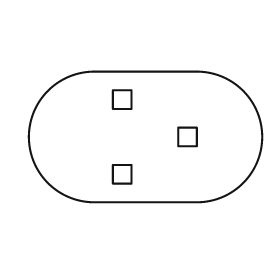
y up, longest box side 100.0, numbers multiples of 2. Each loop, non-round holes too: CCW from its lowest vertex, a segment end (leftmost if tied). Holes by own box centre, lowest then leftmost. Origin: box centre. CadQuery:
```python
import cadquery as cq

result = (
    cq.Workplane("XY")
    .moveTo(-22.0, -28.0)
    .lineTo(22.0, -28.0)
    .threePointArc((50.0, 0.0), (22.0, 28.0))
    .lineTo(-22.0, 28.0)
    .threePointArc((-50.0, 0.0), (-22.0, -28.0))
    .close()
    .moveTo(-14.0, -20.0)
    .lineTo(-6.0, -20.0)
    .lineTo(-6.0, -12.0)
    .lineTo(-14.0, -12.0)
    .close()
    .moveTo(14.0, -4.0)
    .lineTo(22.0, -4.0)
    .lineTo(22.0, 4.0)
    .lineTo(14.0, 4.0)
    .close()
    .moveTo(-14.0, 12.0)
    .lineTo(-6.0, 12.0)
    .lineTo(-6.0, 20.0)
    .lineTo(-14.0, 20.0)
    .close()
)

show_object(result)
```